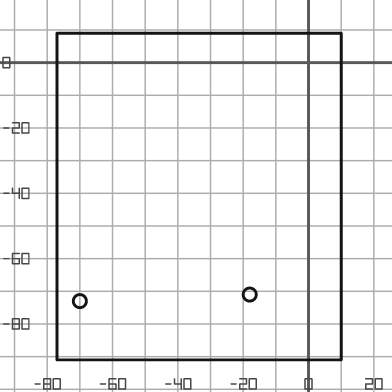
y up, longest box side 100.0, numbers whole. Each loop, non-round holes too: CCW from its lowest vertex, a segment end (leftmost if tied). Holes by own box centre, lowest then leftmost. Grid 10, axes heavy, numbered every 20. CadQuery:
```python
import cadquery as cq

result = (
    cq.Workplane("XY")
    .moveTo(-77.0, -91.0)
    .lineTo(10.0, -91.0)
    .lineTo(10.0, 9.0)
    .lineTo(-77.0, 9.0)
    .close()
    .moveTo(-70.0, -73.0)
    .circle(2.0)
    .moveTo(-18.0, -71.0)
    .circle(2.0)
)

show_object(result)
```